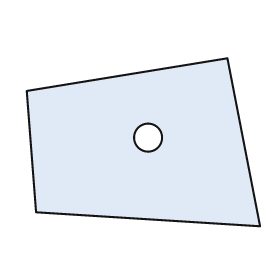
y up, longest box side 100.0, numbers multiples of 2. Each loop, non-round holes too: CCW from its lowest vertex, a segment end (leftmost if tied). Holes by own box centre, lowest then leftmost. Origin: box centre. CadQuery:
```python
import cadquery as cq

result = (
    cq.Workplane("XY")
    .moveTo(50.0, -36.0)
    .lineTo(36.0, 36.0)
    .lineTo(-50.0, 22.0)
    .lineTo(-46.0, -30.0)
    .close()
    .moveTo(2.0, 2.0)
    .circle(6.0)
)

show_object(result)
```